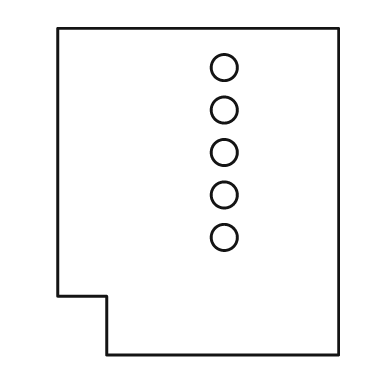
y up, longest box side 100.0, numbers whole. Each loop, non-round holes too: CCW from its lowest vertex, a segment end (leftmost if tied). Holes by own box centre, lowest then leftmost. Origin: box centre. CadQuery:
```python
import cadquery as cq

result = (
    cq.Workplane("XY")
    .moveTo(-28.0, -50.0)
    .lineTo(43.0, -50.0)
    .lineTo(43.0, 50.0)
    .lineTo(-43.0, 50.0)
    .lineTo(-43.0, -32.0)
    .lineTo(-28.0, -32.0)
    .close()
    .moveTo(8.0, -14.0)
    .circle(4.0)
    .moveTo(8.0, -1.0)
    .circle(4.0)
    .moveTo(8.0, 12.0)
    .circle(4.0)
    .moveTo(8.0, 25.0)
    .circle(4.0)
    .moveTo(8.0, 38.0)
    .circle(4.0)
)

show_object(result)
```